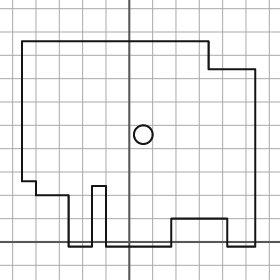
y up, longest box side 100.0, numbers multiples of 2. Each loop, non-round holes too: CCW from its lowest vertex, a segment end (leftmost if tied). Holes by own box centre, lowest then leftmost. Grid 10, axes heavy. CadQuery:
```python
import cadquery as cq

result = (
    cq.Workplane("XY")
    .moveTo(-26.0, -2.0)
    .lineTo(-16.0, -2.0)
    .lineTo(-16.0, 24.0)
    .lineTo(-10.0, 24.0)
    .lineTo(-10.0, -2.0)
    .lineTo(18.0, -2.0)
    .lineTo(18.0, 10.0)
    .lineTo(42.0, 10.0)
    .lineTo(42.0, -2.0)
    .lineTo(54.0, -2.0)
    .lineTo(54.0, 74.0)
    .lineTo(34.0, 74.0)
    .lineTo(34.0, 86.0)
    .lineTo(-46.0, 86.0)
    .lineTo(-46.0, 26.0)
    .lineTo(-40.0, 26.0)
    .lineTo(-40.0, 20.0)
    .lineTo(-26.0, 20.0)
    .close()
    .moveTo(6.0, 46.0)
    .circle(4.0)
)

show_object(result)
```